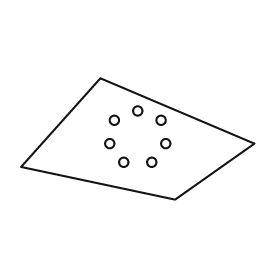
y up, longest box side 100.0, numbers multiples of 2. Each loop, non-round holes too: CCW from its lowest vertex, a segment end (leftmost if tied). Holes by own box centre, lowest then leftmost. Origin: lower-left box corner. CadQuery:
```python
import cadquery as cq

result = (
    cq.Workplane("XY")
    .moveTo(66.0, 0.0)
    .lineTo(100.0, 24.0)
    .lineTo(34.0, 52.0)
    .lineTo(0.0, 14.0)
    .close()
    .moveTo(44.0, 16.0)
    .circle(2.0)
    .moveTo(56.0, 16.0)
    .circle(2.0)
    .moveTo(38.0, 24.0)
    .circle(2.0)
    .moveTo(62.0, 24.0)
    .circle(2.0)
    .moveTo(40.0, 34.0)
    .circle(2.0)
    .moveTo(60.0, 34.0)
    .circle(2.0)
    .moveTo(50.0, 38.0)
    .circle(2.0)
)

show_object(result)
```